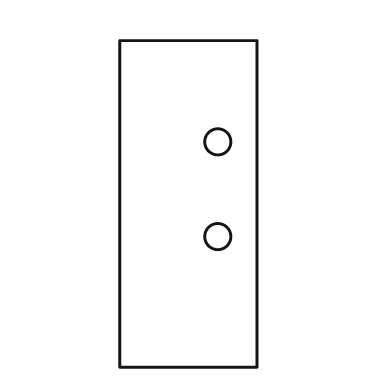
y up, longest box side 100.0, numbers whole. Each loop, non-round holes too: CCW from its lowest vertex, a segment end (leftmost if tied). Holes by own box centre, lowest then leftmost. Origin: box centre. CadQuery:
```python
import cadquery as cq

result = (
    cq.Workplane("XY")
    .moveTo(-21.0, -50.0)
    .lineTo(21.0, -50.0)
    .lineTo(21.0, 50.0)
    .lineTo(-21.0, 50.0)
    .close()
    .moveTo(9.0, -10.0)
    .circle(4.0)
    .moveTo(9.0, 19.0)
    .circle(4.0)
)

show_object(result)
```